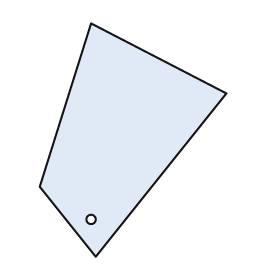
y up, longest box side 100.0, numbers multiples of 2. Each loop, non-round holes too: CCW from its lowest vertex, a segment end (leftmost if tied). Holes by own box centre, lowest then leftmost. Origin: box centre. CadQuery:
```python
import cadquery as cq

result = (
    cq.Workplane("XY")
    .moveTo(-16.0, -50.0)
    .lineTo(40.0, 20.0)
    .lineTo(-18.0, 50.0)
    .lineTo(-40.0, -20.0)
    .close()
    .moveTo(-18.0, -34.0)
    .circle(2.0)
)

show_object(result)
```